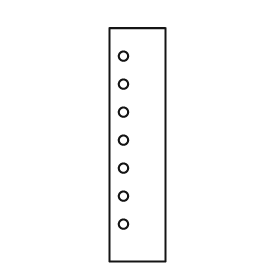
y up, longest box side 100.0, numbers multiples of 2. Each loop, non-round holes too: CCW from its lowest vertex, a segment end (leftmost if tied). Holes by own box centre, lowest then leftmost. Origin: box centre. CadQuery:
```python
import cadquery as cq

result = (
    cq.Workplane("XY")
    .moveTo(-12.0, -50.0)
    .lineTo(12.0, -50.0)
    .lineTo(12.0, 50.0)
    .lineTo(-12.0, 50.0)
    .close()
    .moveTo(-6.0, -34.0)
    .circle(2.0)
    .moveTo(-6.0, -22.0)
    .circle(2.0)
    .moveTo(-6.0, -10.0)
    .circle(2.0)
    .moveTo(-6.0, 2.0)
    .circle(2.0)
    .moveTo(-6.0, 14.0)
    .circle(2.0)
    .moveTo(-6.0, 26.0)
    .circle(2.0)
    .moveTo(-6.0, 38.0)
    .circle(2.0)
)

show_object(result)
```